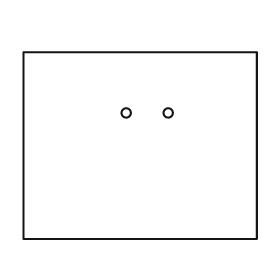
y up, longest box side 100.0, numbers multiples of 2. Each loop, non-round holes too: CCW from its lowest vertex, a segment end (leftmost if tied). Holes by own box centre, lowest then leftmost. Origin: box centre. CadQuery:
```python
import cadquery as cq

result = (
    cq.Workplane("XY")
    .moveTo(-50.0, -40.0)
    .lineTo(50.0, -40.0)
    .lineTo(50.0, 40.0)
    .lineTo(-50.0, 40.0)
    .close()
    .moveTo(-6.0, 14.0)
    .circle(2.0)
    .moveTo(12.0, 14.0)
    .circle(2.0)
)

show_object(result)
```